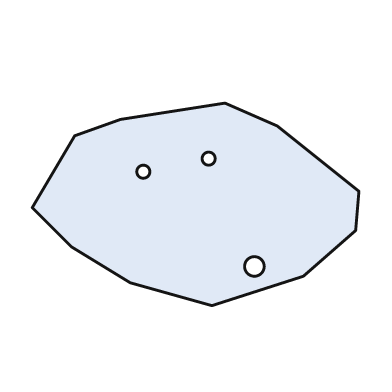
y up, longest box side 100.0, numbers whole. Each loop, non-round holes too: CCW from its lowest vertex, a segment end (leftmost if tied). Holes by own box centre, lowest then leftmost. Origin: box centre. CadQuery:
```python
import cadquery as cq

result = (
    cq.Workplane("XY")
    .moveTo(5.0, -31.0)
    .lineTo(33.0, -22.0)
    .lineTo(49.0, -8.0)
    .lineTo(50.0, 4.0)
    .lineTo(25.0, 24.0)
    .lineTo(9.0, 31.0)
    .lineTo(-23.0, 26.0)
    .lineTo(-37.0, 21.0)
    .lineTo(-50.0, -1.0)
    .lineTo(-38.0, -13.0)
    .lineTo(-20.0, -24.0)
    .close()
    .moveTo(18.0, -19.0)
    .circle(3.0)
    .moveTo(-16.0, 10.0)
    .circle(2.0)
    .moveTo(4.0, 14.0)
    .circle(2.0)
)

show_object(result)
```